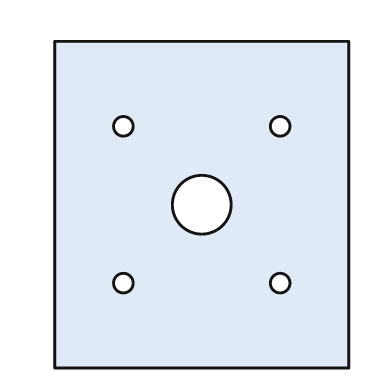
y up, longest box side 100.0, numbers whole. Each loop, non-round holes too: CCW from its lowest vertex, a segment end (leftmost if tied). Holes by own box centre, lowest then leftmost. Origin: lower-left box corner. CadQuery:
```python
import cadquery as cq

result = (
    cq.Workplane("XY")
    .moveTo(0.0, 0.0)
    .lineTo(90.0, 0.0)
    .lineTo(90.0, 100.0)
    .lineTo(0.0, 100.0)
    .close()
    .moveTo(21.0, 26.0)
    .circle(3.0)
    .moveTo(69.0, 26.0)
    .circle(3.0)
    .moveTo(45.0, 50.0)
    .circle(9.0)
    .moveTo(21.0, 74.0)
    .circle(3.0)
    .moveTo(69.0, 74.0)
    .circle(3.0)
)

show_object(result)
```